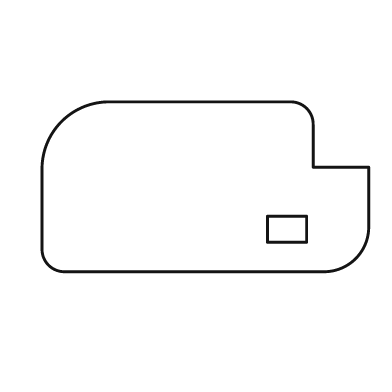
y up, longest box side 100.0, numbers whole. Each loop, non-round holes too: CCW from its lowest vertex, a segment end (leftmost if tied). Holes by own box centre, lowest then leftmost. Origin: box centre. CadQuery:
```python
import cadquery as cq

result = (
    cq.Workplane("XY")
    .moveTo(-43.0, -26.0)
    .lineTo(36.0, -26.0)
    .threePointArc((46.0, -22.0), (50.0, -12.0))
    .lineTo(50.0, 6.0)
    .lineTo(33.0, 6.0)
    .lineTo(33.0, 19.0)
    .threePointArc((31.0, 24.0), (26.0, 26.0))
    .lineTo(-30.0, 26.0)
    .threePointArc((-44.0, 20.0), (-50.0, 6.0))
    .lineTo(-50.0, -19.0)
    .threePointArc((-48.0, -24.0), (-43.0, -26.0))
    .close()
    .moveTo(19.0, -17.0)
    .lineTo(31.0, -17.0)
    .lineTo(31.0, -9.0)
    .lineTo(19.0, -9.0)
    .close()
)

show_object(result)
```